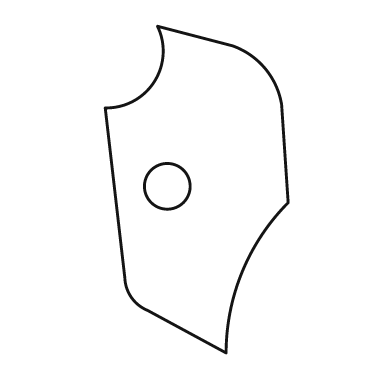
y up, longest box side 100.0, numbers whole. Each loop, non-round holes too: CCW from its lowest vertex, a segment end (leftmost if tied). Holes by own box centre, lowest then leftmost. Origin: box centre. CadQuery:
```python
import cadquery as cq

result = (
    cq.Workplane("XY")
    .moveTo(9.0, -50.0)
    .threePointArc((14.0, -25.0), (28.0, -4.0))
    .lineTo(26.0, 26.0)
    .threePointArc((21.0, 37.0), (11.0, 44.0))
    .lineTo(-12.0, 50.0)
    .threePointArc((-13.0, 33.0), (-28.0, 25.0))
    .lineTo(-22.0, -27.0)
    .threePointArc((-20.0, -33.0), (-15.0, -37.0))
    .close()
    .moveTo(-9.0, 1.0)
    .circle(7.0)
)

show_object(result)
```